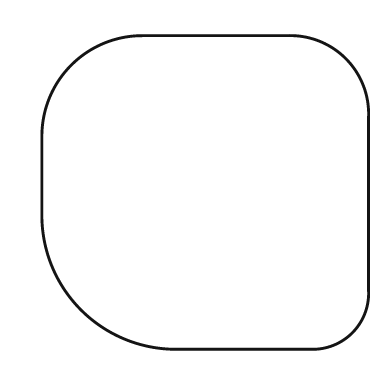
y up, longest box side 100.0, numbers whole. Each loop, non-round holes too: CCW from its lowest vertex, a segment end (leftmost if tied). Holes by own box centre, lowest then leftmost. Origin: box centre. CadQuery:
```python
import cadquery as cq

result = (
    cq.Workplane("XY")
    .moveTo(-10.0, -48.0)
    .lineTo(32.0, -48.0)
    .threePointArc((45.0, -43.0), (50.0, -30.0))
    .lineTo(50.0, 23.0)
    .threePointArc((43.0, 41.0), (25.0, 48.0))
    .lineTo(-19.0, 48.0)
    .threePointArc((-41.0, 39.0), (-50.0, 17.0))
    .lineTo(-50.0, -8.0)
    .threePointArc((-38.0, -36.0), (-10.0, -48.0))
    .close()
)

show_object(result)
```